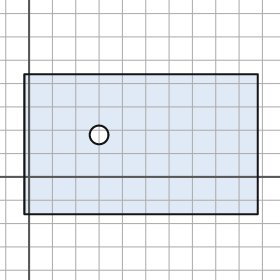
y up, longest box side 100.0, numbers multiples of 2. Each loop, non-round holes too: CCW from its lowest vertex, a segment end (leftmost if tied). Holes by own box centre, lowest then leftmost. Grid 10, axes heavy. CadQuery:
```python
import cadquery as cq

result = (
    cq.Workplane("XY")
    .moveTo(-2.0, -16.0)
    .lineTo(98.0, -16.0)
    .lineTo(98.0, 44.0)
    .lineTo(-2.0, 44.0)
    .close()
    .moveTo(30.0, 18.0)
    .circle(4.0)
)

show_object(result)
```